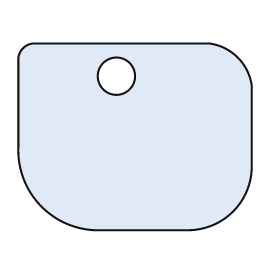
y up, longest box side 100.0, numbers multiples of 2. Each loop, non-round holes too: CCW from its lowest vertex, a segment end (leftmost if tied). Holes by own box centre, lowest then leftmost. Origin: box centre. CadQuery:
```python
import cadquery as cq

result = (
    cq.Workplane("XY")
    .moveTo(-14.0, -40.0)
    .lineTo(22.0, -40.0)
    .threePointArc((42.0, -32.0), (50.0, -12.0))
    .lineTo(50.0, 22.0)
    .threePointArc((44.0, 34.0), (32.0, 40.0))
    .lineTo(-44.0, 40.0)
    .threePointArc((-48.0, 38.0), (-50.0, 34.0))
    .lineTo(-50.0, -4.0)
    .threePointArc((-40.0, -30.0), (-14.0, -40.0))
    .close()
    .moveTo(-8.0, 26.0)
    .circle(8.0)
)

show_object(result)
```